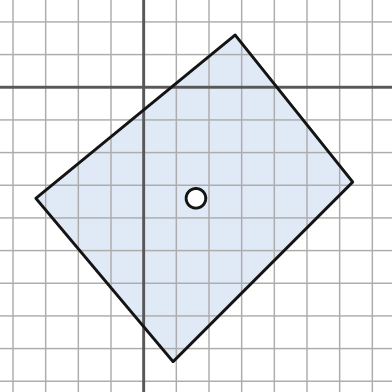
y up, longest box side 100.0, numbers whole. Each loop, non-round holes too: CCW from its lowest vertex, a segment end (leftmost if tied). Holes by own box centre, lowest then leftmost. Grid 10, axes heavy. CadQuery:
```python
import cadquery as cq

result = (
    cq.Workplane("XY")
    .moveTo(9.0, -84.0)
    .lineTo(64.0, -29.0)
    .lineTo(28.0, 16.0)
    .lineTo(-33.0, -34.0)
    .close()
    .moveTo(16.0, -34.0)
    .circle(3.0)
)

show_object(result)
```